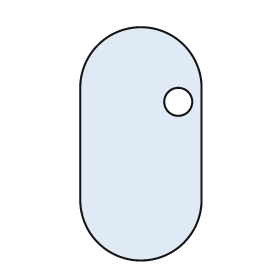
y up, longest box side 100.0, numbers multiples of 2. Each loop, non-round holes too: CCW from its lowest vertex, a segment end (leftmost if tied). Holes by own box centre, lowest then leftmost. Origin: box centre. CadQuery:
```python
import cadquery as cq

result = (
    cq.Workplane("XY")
    .moveTo(-26.0, -24.0)
    .threePointArc((0.0, -50.0), (26.0, -24.0))
    .lineTo(26.0, 24.0)
    .threePointArc((0.0, 50.0), (-26.0, 24.0))
    .close()
    .moveTo(16.0, 18.0)
    .circle(6.0)
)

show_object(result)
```